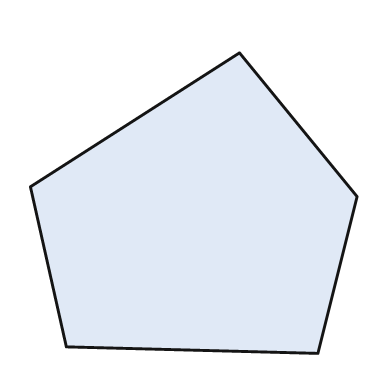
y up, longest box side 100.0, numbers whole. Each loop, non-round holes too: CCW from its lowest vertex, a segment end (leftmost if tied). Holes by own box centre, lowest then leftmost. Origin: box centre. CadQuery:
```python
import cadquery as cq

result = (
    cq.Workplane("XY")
    .moveTo(38.0, -46.0)
    .lineTo(50.0, 2.0)
    .lineTo(14.0, 46.0)
    .lineTo(-50.0, 5.0)
    .lineTo(-39.0, -44.0)
    .close()
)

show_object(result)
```